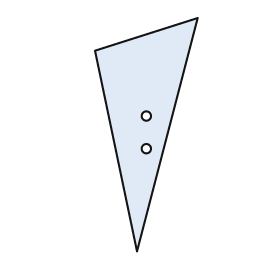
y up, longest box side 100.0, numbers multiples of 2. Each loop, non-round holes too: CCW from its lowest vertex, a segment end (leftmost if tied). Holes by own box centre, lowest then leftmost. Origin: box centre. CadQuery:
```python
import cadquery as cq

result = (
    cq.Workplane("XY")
    .moveTo(-4.0, -50.0)
    .lineTo(22.0, 50.0)
    .lineTo(-22.0, 36.0)
    .close()
    .moveTo(0.0, -6.0)
    .circle(2.0)
    .moveTo(0.0, 8.0)
    .circle(2.0)
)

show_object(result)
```